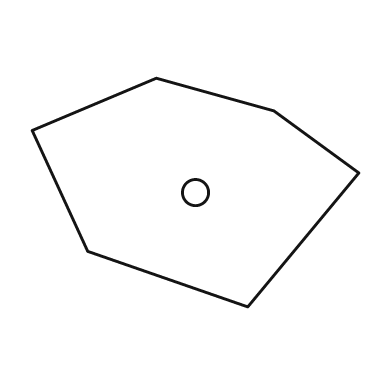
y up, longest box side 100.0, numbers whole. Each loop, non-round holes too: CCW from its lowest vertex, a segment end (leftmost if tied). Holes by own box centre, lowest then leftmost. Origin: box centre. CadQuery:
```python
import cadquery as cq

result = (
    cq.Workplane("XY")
    .moveTo(16.0, -35.0)
    .lineTo(50.0, 6.0)
    .lineTo(24.0, 25.0)
    .lineTo(-12.0, 35.0)
    .lineTo(-50.0, 19.0)
    .lineTo(-33.0, -18.0)
    .close()
    .moveTo(0.0, 0.0)
    .circle(4.0)
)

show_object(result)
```